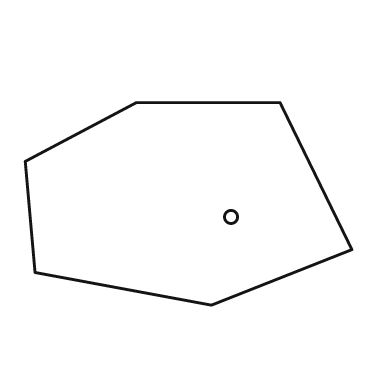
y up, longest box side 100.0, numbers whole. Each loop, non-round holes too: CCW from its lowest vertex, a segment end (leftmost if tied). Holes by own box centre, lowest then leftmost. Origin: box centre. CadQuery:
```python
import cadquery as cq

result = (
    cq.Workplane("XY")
    .moveTo(7.0, -31.0)
    .lineTo(50.0, -14.0)
    .lineTo(28.0, 31.0)
    .lineTo(-16.0, 31.0)
    .lineTo(-50.0, 13.0)
    .lineTo(-47.0, -21.0)
    .close()
    .moveTo(13.0, -4.0)
    .circle(2.0)
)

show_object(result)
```